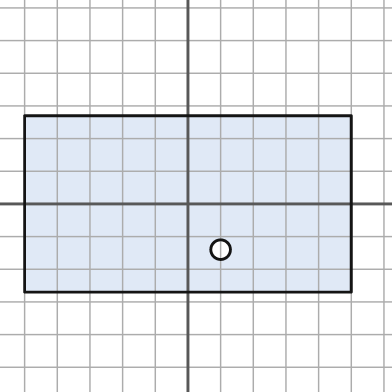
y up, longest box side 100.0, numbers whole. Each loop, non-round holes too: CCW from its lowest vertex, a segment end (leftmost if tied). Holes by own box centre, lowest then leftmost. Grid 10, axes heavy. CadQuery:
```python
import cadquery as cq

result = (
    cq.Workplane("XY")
    .moveTo(-50.0, -27.0)
    .lineTo(50.0, -27.0)
    .lineTo(50.0, 27.0)
    .lineTo(-50.0, 27.0)
    .close()
    .moveTo(10.0, -14.0)
    .circle(3.0)
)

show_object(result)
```